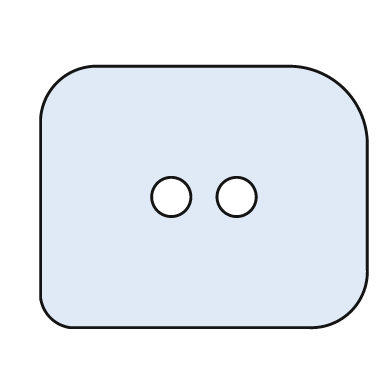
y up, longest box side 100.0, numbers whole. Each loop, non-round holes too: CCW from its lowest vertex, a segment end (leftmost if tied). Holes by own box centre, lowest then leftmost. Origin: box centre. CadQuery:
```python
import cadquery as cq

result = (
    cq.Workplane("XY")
    .moveTo(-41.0, -40.0)
    .lineTo(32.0, -40.0)
    .threePointArc((45.0, -35.0), (50.0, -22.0))
    .lineTo(50.0, 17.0)
    .threePointArc((43.0, 33.0), (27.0, 40.0))
    .lineTo(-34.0, 40.0)
    .threePointArc((-45.0, 35.0), (-50.0, 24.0))
    .lineTo(-50.0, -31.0)
    .threePointArc((-47.0, -37.0), (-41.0, -40.0))
    .close()
    .moveTo(-10.0, 0.0)
    .circle(6.0)
    .moveTo(10.0, 0.0)
    .circle(6.0)
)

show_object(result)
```